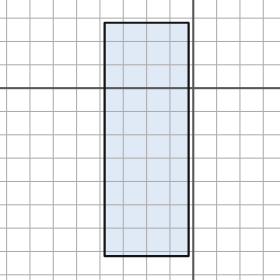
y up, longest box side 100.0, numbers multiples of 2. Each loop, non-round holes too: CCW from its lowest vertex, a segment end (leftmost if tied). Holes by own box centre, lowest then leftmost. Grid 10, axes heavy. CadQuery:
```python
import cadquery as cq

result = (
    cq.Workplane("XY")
    .moveTo(-38.0, -72.0)
    .lineTo(-2.0, -72.0)
    .lineTo(-2.0, 28.0)
    .lineTo(-38.0, 28.0)
    .close()
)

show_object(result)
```